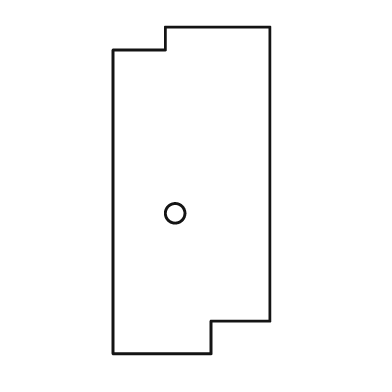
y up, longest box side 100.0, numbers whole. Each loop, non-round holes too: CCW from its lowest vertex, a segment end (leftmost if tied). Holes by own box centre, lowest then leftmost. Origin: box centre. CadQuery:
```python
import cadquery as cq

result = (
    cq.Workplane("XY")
    .moveTo(-24.0, -50.0)
    .lineTo(6.0, -50.0)
    .lineTo(6.0, -40.0)
    .lineTo(24.0, -40.0)
    .lineTo(24.0, 50.0)
    .lineTo(-8.0, 50.0)
    .lineTo(-8.0, 43.0)
    .lineTo(-24.0, 43.0)
    .close()
    .moveTo(-5.0, -7.0)
    .circle(3.0)
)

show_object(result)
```